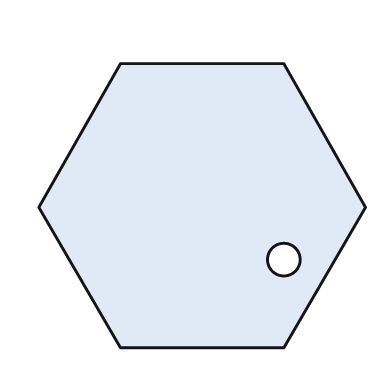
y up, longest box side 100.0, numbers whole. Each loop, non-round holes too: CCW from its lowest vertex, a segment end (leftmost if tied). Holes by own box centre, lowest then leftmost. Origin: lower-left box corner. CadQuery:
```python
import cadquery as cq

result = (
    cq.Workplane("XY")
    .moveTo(25.0, 0.0)
    .lineTo(75.0, 0.0)
    .lineTo(100.0, 43.0)
    .lineTo(75.0, 87.0)
    .lineTo(25.0, 87.0)
    .lineTo(0.0, 43.0)
    .close()
    .moveTo(75.0, 27.0)
    .circle(5.0)
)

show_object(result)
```